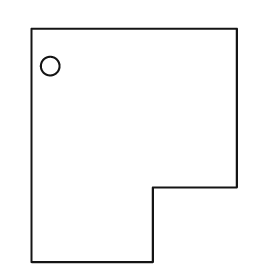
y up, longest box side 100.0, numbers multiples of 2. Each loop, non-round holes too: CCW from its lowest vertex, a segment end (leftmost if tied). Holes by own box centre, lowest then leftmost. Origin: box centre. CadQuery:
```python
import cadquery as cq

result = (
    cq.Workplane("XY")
    .moveTo(-44.0, -50.0)
    .lineTo(8.0, -50.0)
    .lineTo(8.0, -18.0)
    .lineTo(44.0, -18.0)
    .lineTo(44.0, 50.0)
    .lineTo(-44.0, 50.0)
    .close()
    .moveTo(-36.0, 34.0)
    .circle(4.0)
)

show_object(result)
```